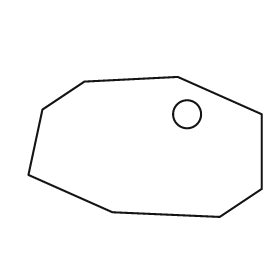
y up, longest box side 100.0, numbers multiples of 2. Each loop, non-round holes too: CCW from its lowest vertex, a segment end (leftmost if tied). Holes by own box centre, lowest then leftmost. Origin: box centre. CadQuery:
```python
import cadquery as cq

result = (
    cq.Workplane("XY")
    .moveTo(32.0, -30.0)
    .lineTo(50.0, -18.0)
    .lineTo(50.0, 14.0)
    .lineTo(14.0, 30.0)
    .lineTo(-26.0, 28.0)
    .lineTo(-44.0, 16.0)
    .lineTo(-50.0, -12.0)
    .lineTo(-14.0, -28.0)
    .close()
    .moveTo(18.0, 14.0)
    .circle(6.0)
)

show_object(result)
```